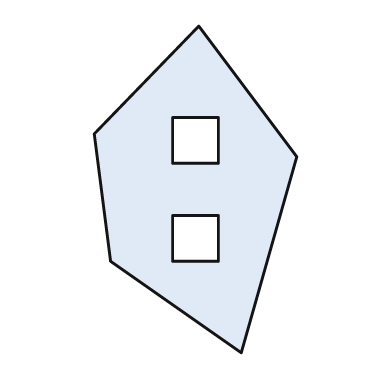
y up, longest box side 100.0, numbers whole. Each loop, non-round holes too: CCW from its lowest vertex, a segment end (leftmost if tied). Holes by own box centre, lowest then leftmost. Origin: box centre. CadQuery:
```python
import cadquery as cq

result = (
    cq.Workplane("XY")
    .moveTo(14.0, -50.0)
    .lineTo(31.0, 10.0)
    .lineTo(1.0, 50.0)
    .lineTo(-31.0, 17.0)
    .lineTo(-26.0, -22.0)
    .close()
    .moveTo(-7.0, -22.0)
    .lineTo(7.0, -22.0)
    .lineTo(7.0, -8.0)
    .lineTo(-7.0, -8.0)
    .close()
    .moveTo(-7.0, 8.0)
    .lineTo(7.0, 8.0)
    .lineTo(7.0, 22.0)
    .lineTo(-7.0, 22.0)
    .close()
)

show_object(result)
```